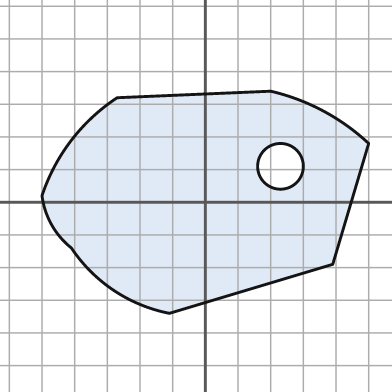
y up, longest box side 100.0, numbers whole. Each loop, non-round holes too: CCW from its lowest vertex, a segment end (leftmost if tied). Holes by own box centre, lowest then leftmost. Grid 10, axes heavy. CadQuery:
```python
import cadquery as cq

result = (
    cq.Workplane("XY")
    .moveTo(-11.0, -34.0)
    .lineTo(39.0, -19.0)
    .lineTo(50.0, 18.0)
    .threePointArc((36.0, 28.0), (20.0, 34.0))
    .lineTo(-27.0, 32.0)
    .threePointArc((-41.0, 19.0), (-50.0, 2.0))
    .threePointArc((-47.0, -7.0), (-41.0, -14.0))
    .threePointArc((-28.0, -27.0), (-11.0, -34.0))
    .close()
    .moveTo(23.0, 11.0)
    .circle(7.0)
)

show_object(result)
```